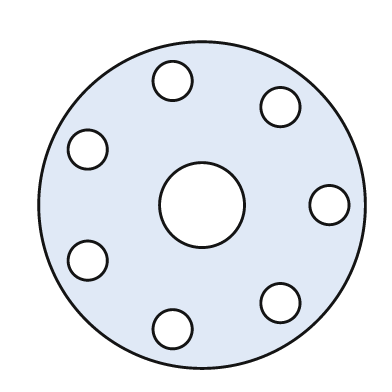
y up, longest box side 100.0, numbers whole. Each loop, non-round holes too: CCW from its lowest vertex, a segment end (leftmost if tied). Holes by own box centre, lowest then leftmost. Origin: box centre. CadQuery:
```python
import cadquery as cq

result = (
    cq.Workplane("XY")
    .moveTo(0.0, 0.0)
    .circle(50.0)
    .moveTo(-9.0, -38.0)
    .circle(6.0)
    .moveTo(24.0, -30.0)
    .circle(6.0)
    .moveTo(-35.0, -17.0)
    .circle(6.0)
    .moveTo(0.0, 0.0)
    .circle(13.0)
    .moveTo(39.0, 0.0)
    .circle(6.0)
    .moveTo(-35.0, 17.0)
    .circle(6.0)
    .moveTo(24.0, 30.0)
    .circle(6.0)
    .moveTo(-9.0, 38.0)
    .circle(6.0)
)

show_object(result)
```